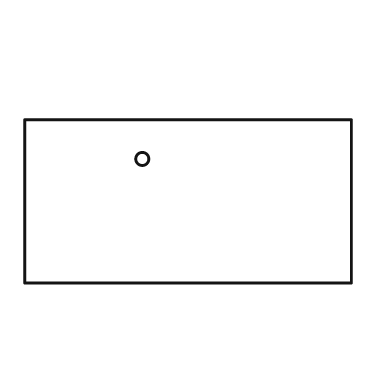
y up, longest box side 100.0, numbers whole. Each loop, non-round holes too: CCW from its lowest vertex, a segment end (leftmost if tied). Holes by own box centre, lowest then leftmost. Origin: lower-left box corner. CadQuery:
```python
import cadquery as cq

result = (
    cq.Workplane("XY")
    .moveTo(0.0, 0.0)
    .lineTo(100.0, 0.0)
    .lineTo(100.0, 50.0)
    .lineTo(0.0, 50.0)
    .close()
    .moveTo(36.0, 38.0)
    .circle(2.0)
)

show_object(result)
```